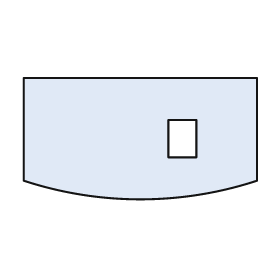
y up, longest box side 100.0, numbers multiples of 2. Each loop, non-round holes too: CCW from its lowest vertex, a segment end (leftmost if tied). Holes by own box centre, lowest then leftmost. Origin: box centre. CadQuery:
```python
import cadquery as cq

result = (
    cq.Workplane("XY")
    .moveTo(-50.0, -18.0)
    .threePointArc((0.0, -26.0), (50.0, -18.0))
    .lineTo(50.0, 26.0)
    .lineTo(-50.0, 26.0)
    .close()
    .moveTo(12.0, -8.0)
    .lineTo(24.0, -8.0)
    .lineTo(24.0, 8.0)
    .lineTo(12.0, 8.0)
    .close()
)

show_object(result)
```